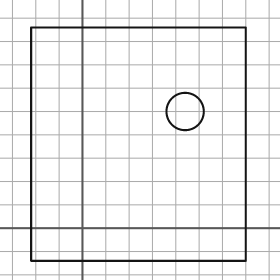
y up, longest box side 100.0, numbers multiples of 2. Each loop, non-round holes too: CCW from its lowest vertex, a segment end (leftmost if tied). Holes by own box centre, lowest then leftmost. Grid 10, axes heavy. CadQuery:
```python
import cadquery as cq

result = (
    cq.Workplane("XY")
    .moveTo(-22.0, -14.0)
    .lineTo(70.0, -14.0)
    .lineTo(70.0, 86.0)
    .lineTo(-22.0, 86.0)
    .close()
    .moveTo(44.0, 50.0)
    .circle(8.0)
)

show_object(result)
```